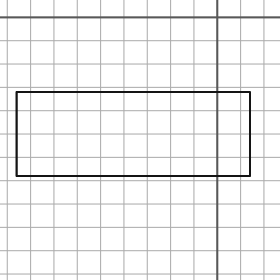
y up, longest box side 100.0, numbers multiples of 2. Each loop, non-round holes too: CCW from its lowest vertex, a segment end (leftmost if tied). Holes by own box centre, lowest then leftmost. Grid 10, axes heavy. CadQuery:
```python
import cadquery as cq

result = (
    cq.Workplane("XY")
    .moveTo(-86.0, -68.0)
    .lineTo(14.0, -68.0)
    .lineTo(14.0, -32.0)
    .lineTo(-86.0, -32.0)
    .close()
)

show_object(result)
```